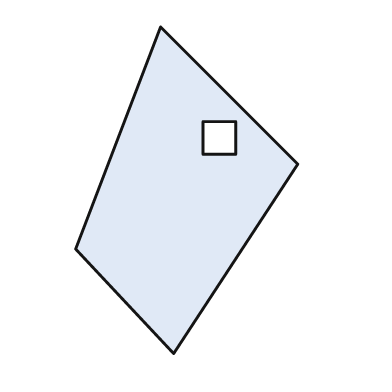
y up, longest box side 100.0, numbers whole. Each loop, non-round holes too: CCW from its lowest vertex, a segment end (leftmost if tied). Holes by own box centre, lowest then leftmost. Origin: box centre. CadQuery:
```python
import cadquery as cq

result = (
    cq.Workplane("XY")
    .moveTo(-4.0, -50.0)
    .lineTo(34.0, 8.0)
    .lineTo(-8.0, 50.0)
    .lineTo(-34.0, -18.0)
    .close()
    .moveTo(5.0, 11.0)
    .lineTo(15.0, 11.0)
    .lineTo(15.0, 21.0)
    .lineTo(5.0, 21.0)
    .close()
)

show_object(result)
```